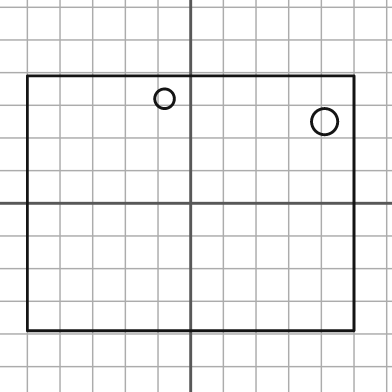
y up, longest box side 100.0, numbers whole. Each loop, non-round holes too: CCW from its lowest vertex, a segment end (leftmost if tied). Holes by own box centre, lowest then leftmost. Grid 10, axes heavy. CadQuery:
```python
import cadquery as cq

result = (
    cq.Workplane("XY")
    .moveTo(-50.0, -39.0)
    .lineTo(50.0, -39.0)
    .lineTo(50.0, 39.0)
    .lineTo(-50.0, 39.0)
    .close()
    .moveTo(41.0, 25.0)
    .circle(4.0)
    .moveTo(-8.0, 32.0)
    .circle(3.0)
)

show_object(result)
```